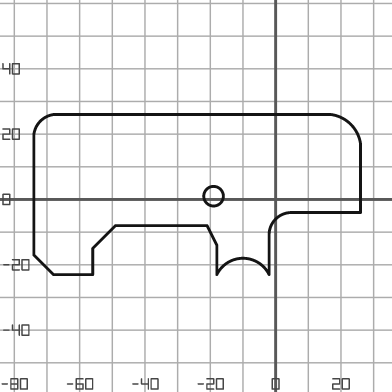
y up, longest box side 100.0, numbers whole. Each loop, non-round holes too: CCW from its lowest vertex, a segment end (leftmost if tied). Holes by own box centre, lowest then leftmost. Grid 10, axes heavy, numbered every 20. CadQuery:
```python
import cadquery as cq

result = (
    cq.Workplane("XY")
    .moveTo(-68.0, -23.0)
    .lineTo(-56.0, -23.0)
    .lineTo(-56.0, -15.0)
    .lineTo(-49.0, -8.0)
    .lineTo(-21.0, -8.0)
    .lineTo(-18.0, -14.0)
    .lineTo(-18.0, -23.0)
    .threePointArc((-10.0, -18.0), (-2.0, -23.0))
    .lineTo(-2.0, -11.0)
    .threePointArc((0.0, -6.0), (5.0, -4.0))
    .lineTo(26.0, -4.0)
    .lineTo(26.0, 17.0)
    .threePointArc((23.0, 23.0), (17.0, 26.0))
    .lineTo(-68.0, 26.0)
    .threePointArc((-72.0, 24.0), (-74.0, 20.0))
    .lineTo(-74.0, -17.0)
    .close()
    .moveTo(-19.0, 1.0)
    .circle(3.0)
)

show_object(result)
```